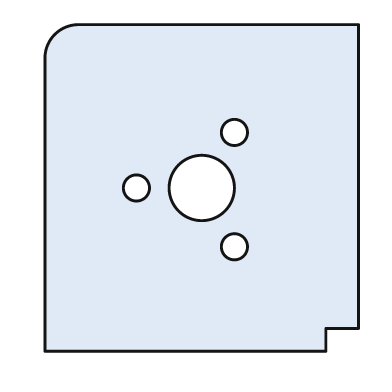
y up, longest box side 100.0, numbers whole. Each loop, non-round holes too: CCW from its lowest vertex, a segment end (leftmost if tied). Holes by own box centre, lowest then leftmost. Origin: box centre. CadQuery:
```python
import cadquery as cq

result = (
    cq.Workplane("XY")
    .moveTo(-48.0, -50.0)
    .lineTo(38.0, -50.0)
    .lineTo(38.0, -43.0)
    .lineTo(48.0, -43.0)
    .lineTo(48.0, 50.0)
    .lineTo(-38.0, 50.0)
    .threePointArc((-45.0, 47.0), (-48.0, 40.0))
    .close()
    .moveTo(10.0, -18.0)
    .circle(4.0)
    .moveTo(-20.0, 0.0)
    .circle(4.0)
    .moveTo(0.0, 0.0)
    .circle(10.0)
    .moveTo(10.0, 17.0)
    .circle(4.0)
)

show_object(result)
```